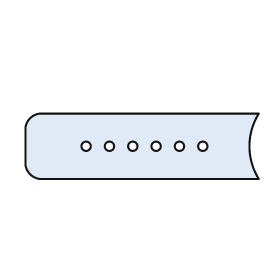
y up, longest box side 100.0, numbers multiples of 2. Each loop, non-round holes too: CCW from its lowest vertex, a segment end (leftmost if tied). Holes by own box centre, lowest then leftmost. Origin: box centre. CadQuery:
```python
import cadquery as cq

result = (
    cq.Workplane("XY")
    .moveTo(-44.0, -14.0)
    .lineTo(50.0, -14.0)
    .threePointArc((46.0, 0.0), (50.0, 14.0))
    .lineTo(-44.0, 14.0)
    .threePointArc((-48.0, 12.0), (-50.0, 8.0))
    .lineTo(-50.0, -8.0)
    .threePointArc((-48.0, -12.0), (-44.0, -14.0))
    .close()
    .moveTo(-24.0, 0.0)
    .circle(2.0)
    .moveTo(-14.0, 0.0)
    .circle(2.0)
    .moveTo(-4.0, 0.0)
    .circle(2.0)
    .moveTo(6.0, 0.0)
    .circle(2.0)
    .moveTo(16.0, 0.0)
    .circle(2.0)
    .moveTo(26.0, 0.0)
    .circle(2.0)
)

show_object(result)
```